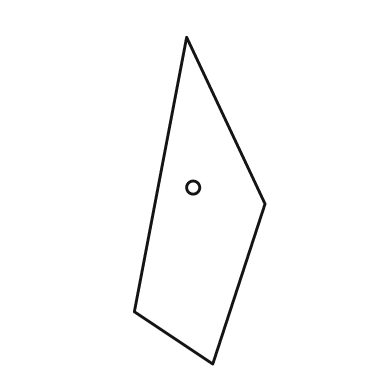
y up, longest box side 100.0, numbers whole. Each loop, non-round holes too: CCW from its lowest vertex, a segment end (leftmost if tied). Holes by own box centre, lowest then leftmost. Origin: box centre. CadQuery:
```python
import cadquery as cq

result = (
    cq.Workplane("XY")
    .moveTo(4.0, -50.0)
    .lineTo(20.0, -1.0)
    .lineTo(-4.0, 50.0)
    .lineTo(-20.0, -34.0)
    .close()
    .moveTo(-2.0, 4.0)
    .circle(2.0)
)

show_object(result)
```